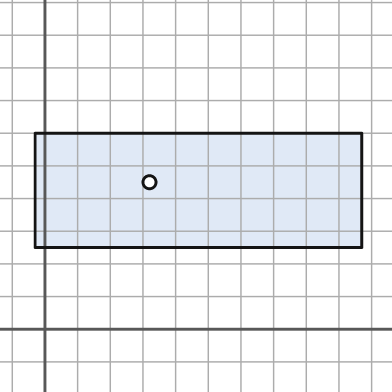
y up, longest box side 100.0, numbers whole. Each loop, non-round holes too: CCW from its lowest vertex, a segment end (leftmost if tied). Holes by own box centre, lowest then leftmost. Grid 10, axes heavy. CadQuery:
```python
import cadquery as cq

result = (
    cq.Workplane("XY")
    .moveTo(-3.0, 25.0)
    .lineTo(97.0, 25.0)
    .lineTo(97.0, 60.0)
    .lineTo(-3.0, 60.0)
    .close()
    .moveTo(32.0, 45.0)
    .circle(2.0)
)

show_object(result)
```